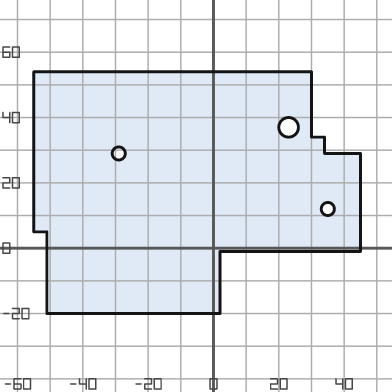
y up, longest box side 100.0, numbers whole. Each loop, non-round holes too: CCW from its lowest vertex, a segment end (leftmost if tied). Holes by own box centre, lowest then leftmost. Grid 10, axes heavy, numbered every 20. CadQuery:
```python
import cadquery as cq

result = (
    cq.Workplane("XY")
    .moveTo(-51.0, -20.0)
    .lineTo(2.0, -20.0)
    .lineTo(2.0, -1.0)
    .lineTo(45.0, -1.0)
    .lineTo(45.0, 29.0)
    .lineTo(34.0, 29.0)
    .lineTo(34.0, 34.0)
    .lineTo(30.0, 34.0)
    .lineTo(30.0, 54.0)
    .lineTo(-55.0, 54.0)
    .lineTo(-55.0, 5.0)
    .lineTo(-51.0, 5.0)
    .close()
    .moveTo(35.0, 12.0)
    .circle(2.0)
    .moveTo(-29.0, 29.0)
    .circle(2.0)
    .moveTo(23.0, 37.0)
    .circle(3.0)
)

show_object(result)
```